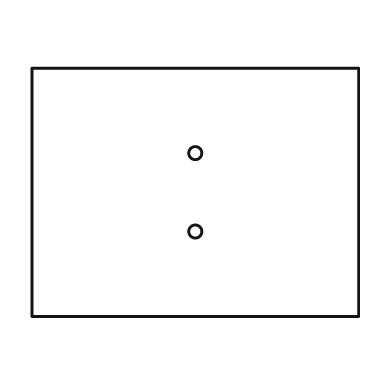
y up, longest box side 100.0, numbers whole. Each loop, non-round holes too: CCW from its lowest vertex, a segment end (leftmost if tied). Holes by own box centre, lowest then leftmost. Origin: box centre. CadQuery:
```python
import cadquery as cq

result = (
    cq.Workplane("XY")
    .moveTo(-50.0, -38.0)
    .lineTo(50.0, -38.0)
    .lineTo(50.0, 38.0)
    .lineTo(-50.0, 38.0)
    .close()
    .moveTo(0.0, -12.0)
    .circle(2.0)
    .moveTo(0.0, 12.0)
    .circle(2.0)
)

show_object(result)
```